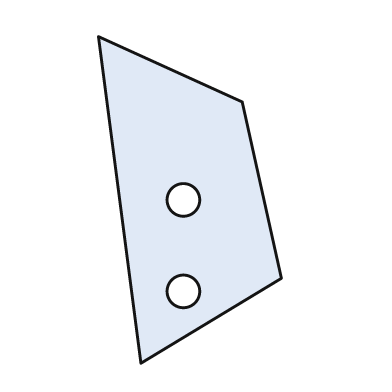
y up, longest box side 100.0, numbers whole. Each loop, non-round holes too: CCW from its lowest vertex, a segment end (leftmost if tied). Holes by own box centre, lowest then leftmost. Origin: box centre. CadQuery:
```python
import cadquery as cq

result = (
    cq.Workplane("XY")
    .moveTo(-15.0, -50.0)
    .lineTo(28.0, -24.0)
    .lineTo(16.0, 30.0)
    .lineTo(-28.0, 50.0)
    .close()
    .moveTo(-2.0, -28.0)
    .circle(5.0)
    .moveTo(-2.0, 0.0)
    .circle(5.0)
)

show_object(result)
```